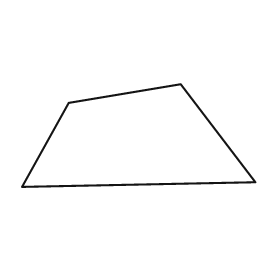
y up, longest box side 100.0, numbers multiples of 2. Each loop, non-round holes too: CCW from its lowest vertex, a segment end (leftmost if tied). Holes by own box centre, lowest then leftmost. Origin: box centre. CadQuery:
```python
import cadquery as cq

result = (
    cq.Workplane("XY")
    .moveTo(-50.0, -22.0)
    .lineTo(50.0, -20.0)
    .lineTo(18.0, 22.0)
    .lineTo(-30.0, 14.0)
    .close()
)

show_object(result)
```